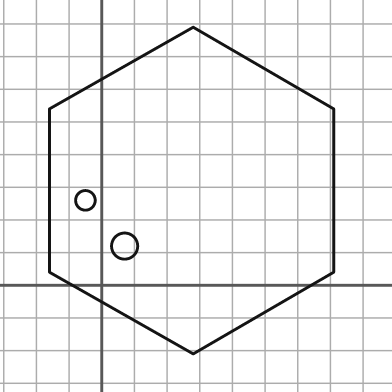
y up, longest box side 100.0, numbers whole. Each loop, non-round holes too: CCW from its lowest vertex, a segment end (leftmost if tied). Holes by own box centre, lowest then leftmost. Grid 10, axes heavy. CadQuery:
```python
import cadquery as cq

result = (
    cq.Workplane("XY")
    .moveTo(28.0, -21.0)
    .lineTo(71.0, 4.0)
    .lineTo(71.0, 54.0)
    .lineTo(28.0, 79.0)
    .lineTo(-16.0, 54.0)
    .lineTo(-16.0, 4.0)
    .close()
    .moveTo(7.0, 12.0)
    .circle(4.0)
    .moveTo(-5.0, 26.0)
    .circle(3.0)
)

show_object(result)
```